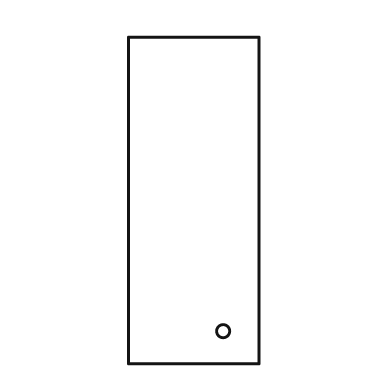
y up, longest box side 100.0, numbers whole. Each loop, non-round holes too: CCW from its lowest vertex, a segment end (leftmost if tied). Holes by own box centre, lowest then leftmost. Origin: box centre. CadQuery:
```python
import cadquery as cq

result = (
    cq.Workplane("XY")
    .moveTo(-20.0, -50.0)
    .lineTo(20.0, -50.0)
    .lineTo(20.0, 50.0)
    .lineTo(-20.0, 50.0)
    .close()
    .moveTo(9.0, -40.0)
    .circle(2.0)
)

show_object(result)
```